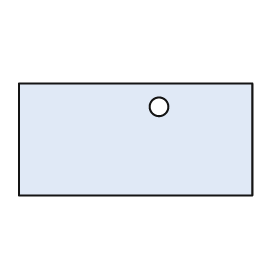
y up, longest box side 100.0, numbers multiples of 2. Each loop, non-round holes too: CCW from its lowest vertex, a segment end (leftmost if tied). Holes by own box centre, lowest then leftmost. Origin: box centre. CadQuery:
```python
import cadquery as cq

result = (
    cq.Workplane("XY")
    .moveTo(-50.0, -24.0)
    .lineTo(50.0, -24.0)
    .lineTo(50.0, 24.0)
    .lineTo(-50.0, 24.0)
    .close()
    .moveTo(10.0, 14.0)
    .circle(4.0)
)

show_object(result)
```